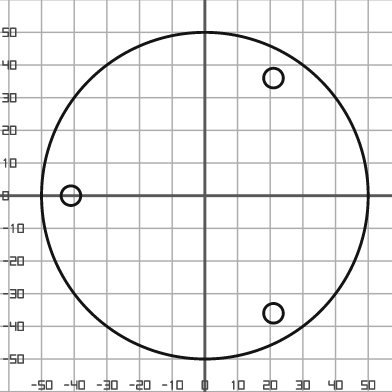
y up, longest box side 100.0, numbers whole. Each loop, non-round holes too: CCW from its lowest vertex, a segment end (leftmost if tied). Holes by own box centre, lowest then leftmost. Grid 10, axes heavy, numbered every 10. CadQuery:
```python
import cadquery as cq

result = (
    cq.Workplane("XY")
    .moveTo(0.0, 0.0)
    .circle(50.0)
    .moveTo(21.0, -36.0)
    .circle(3.0)
    .moveTo(-41.0, 0.0)
    .circle(3.0)
    .moveTo(21.0, 36.0)
    .circle(3.0)
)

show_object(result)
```